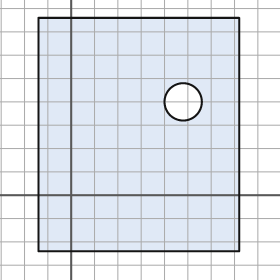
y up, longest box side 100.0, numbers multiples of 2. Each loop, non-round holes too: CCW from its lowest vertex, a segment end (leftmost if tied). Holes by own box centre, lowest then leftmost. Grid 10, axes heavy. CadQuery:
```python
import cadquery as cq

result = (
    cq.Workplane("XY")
    .moveTo(-14.0, -24.0)
    .lineTo(72.0, -24.0)
    .lineTo(72.0, 76.0)
    .lineTo(-14.0, 76.0)
    .close()
    .moveTo(48.0, 40.0)
    .circle(8.0)
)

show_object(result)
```